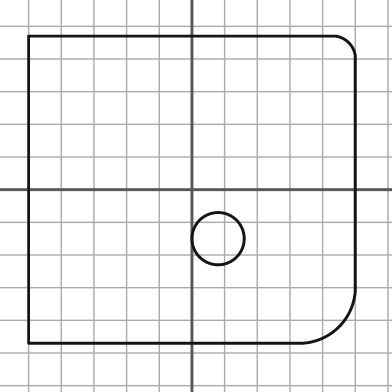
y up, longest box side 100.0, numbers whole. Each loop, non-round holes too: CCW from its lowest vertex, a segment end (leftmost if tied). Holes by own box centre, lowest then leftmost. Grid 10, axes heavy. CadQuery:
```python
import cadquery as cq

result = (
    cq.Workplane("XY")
    .moveTo(-50.0, -47.0)
    .lineTo(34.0, -47.0)
    .threePointArc((45.0, -42.0), (50.0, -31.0))
    .lineTo(50.0, 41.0)
    .threePointArc((48.0, 45.0), (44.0, 47.0))
    .lineTo(-50.0, 47.0)
    .close()
    .moveTo(8.0, -15.0)
    .circle(8.0)
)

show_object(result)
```